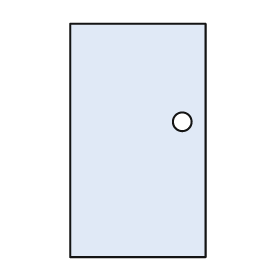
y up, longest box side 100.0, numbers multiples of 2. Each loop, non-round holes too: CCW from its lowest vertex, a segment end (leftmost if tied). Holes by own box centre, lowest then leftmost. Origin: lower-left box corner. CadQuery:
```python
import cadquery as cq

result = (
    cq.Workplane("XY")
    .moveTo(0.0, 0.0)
    .lineTo(58.0, 0.0)
    .lineTo(58.0, 100.0)
    .lineTo(0.0, 100.0)
    .close()
    .moveTo(48.0, 58.0)
    .circle(4.0)
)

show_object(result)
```